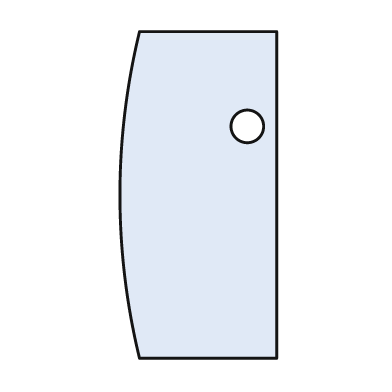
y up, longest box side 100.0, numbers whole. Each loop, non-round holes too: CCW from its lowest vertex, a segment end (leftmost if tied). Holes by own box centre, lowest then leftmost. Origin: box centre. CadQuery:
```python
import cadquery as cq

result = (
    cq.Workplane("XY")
    .moveTo(-18.0, -50.0)
    .lineTo(24.0, -50.0)
    .lineTo(24.0, 50.0)
    .lineTo(-18.0, 50.0)
    .threePointArc((-24.0, 0.0), (-18.0, -50.0))
    .close()
    .moveTo(15.0, 21.0)
    .circle(5.0)
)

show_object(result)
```